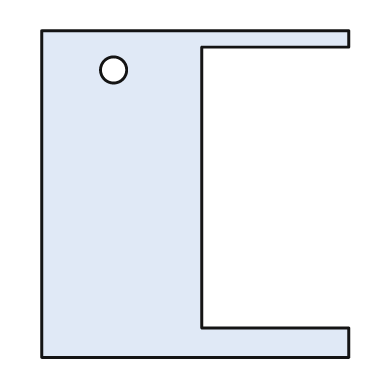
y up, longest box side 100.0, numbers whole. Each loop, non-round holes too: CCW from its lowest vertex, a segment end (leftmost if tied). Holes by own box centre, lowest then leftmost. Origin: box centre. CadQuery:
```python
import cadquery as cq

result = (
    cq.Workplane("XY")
    .moveTo(-47.0, -50.0)
    .lineTo(47.0, -50.0)
    .lineTo(47.0, -41.0)
    .lineTo(2.0, -41.0)
    .lineTo(2.0, 45.0)
    .lineTo(47.0, 45.0)
    .lineTo(47.0, 50.0)
    .lineTo(-47.0, 50.0)
    .close()
    .moveTo(-25.0, 38.0)
    .circle(4.0)
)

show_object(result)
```